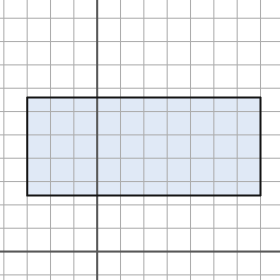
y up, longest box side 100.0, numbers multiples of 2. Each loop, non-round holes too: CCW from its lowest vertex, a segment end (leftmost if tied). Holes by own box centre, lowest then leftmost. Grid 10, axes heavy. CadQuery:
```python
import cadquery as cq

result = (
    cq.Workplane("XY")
    .moveTo(-30.0, 24.0)
    .lineTo(70.0, 24.0)
    .lineTo(70.0, 66.0)
    .lineTo(-30.0, 66.0)
    .close()
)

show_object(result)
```